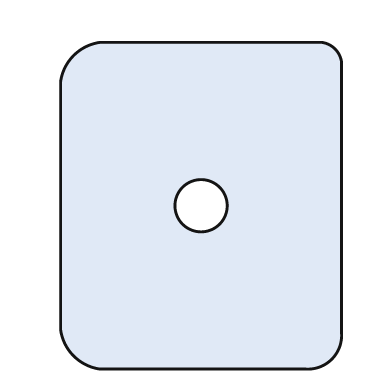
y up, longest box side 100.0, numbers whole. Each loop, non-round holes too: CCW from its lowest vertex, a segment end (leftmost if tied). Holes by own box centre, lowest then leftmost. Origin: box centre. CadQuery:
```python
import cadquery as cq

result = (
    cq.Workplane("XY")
    .moveTo(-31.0, -50.0)
    .lineTo(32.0, -50.0)
    .threePointArc((40.0, -47.0), (43.0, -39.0))
    .lineTo(43.0, 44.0)
    .threePointArc((41.0, 48.0), (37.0, 50.0))
    .lineTo(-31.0, 50.0)
    .threePointArc((-39.0, 46.0), (-43.0, 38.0))
    .lineTo(-43.0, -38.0)
    .threePointArc((-39.0, -46.0), (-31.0, -50.0))
    .close()
    .moveTo(0.0, 0.0)
    .circle(8.0)
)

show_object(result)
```